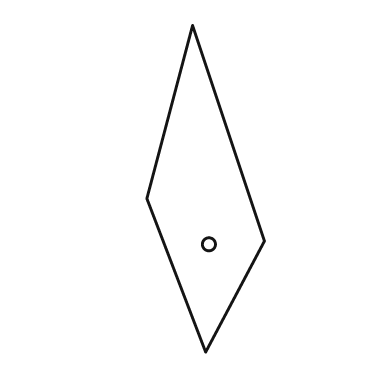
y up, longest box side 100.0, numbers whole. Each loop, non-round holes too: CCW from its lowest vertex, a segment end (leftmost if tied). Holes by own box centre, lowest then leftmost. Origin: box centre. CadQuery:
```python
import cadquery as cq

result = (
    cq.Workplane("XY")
    .moveTo(0.0, -50.0)
    .lineTo(18.0, -16.0)
    .lineTo(-4.0, 50.0)
    .lineTo(-18.0, -3.0)
    .close()
    .moveTo(1.0, -17.0)
    .circle(2.0)
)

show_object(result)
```